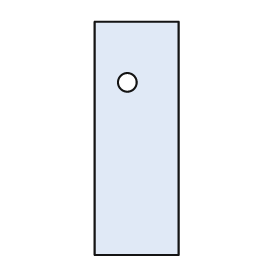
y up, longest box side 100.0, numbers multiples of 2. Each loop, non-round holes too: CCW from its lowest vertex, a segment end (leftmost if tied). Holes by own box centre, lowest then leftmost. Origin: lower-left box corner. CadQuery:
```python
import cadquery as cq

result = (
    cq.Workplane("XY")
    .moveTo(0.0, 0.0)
    .lineTo(36.0, 0.0)
    .lineTo(36.0, 100.0)
    .lineTo(0.0, 100.0)
    .close()
    .moveTo(14.0, 74.0)
    .circle(4.0)
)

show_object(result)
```